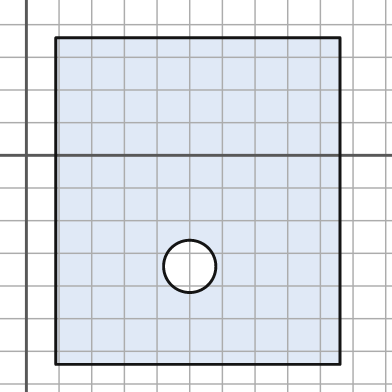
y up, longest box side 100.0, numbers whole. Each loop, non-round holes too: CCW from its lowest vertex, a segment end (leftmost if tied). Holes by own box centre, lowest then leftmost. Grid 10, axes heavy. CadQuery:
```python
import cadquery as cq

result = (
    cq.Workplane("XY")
    .moveTo(9.0, -64.0)
    .lineTo(96.0, -64.0)
    .lineTo(96.0, 36.0)
    .lineTo(9.0, 36.0)
    .close()
    .moveTo(50.0, -34.0)
    .circle(8.0)
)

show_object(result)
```